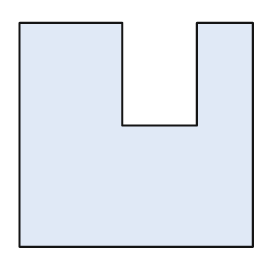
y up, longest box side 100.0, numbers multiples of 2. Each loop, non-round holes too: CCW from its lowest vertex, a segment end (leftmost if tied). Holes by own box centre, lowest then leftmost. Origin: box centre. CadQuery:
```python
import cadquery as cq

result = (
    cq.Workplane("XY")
    .moveTo(-50.0, -48.0)
    .lineTo(50.0, -48.0)
    .lineTo(50.0, 48.0)
    .lineTo(26.0, 48.0)
    .lineTo(26.0, 4.0)
    .lineTo(-6.0, 4.0)
    .lineTo(-6.0, 48.0)
    .lineTo(-50.0, 48.0)
    .close()
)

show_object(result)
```